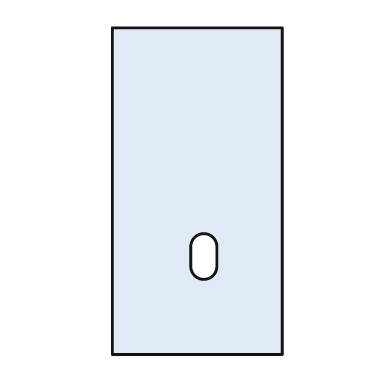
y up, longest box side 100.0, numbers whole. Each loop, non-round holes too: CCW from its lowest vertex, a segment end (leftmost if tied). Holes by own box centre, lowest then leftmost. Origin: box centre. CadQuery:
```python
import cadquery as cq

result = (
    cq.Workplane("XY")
    .moveTo(-26.0, -50.0)
    .lineTo(26.0, -50.0)
    .lineTo(26.0, 50.0)
    .lineTo(-26.0, 50.0)
    .close()
    .moveTo(-2.0, -23.0)
    .threePointArc((2.0, -27.0), (6.0, -23.0))
    .lineTo(6.0, -17.0)
    .threePointArc((2.0, -13.0), (-2.0, -17.0))
    .close()
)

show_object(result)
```